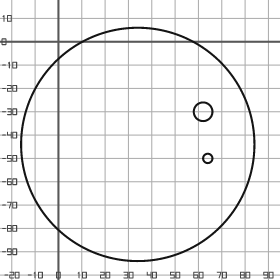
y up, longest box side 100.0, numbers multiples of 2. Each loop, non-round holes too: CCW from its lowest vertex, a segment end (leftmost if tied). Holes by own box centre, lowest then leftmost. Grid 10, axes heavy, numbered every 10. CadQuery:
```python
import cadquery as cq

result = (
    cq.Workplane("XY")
    .moveTo(34.0, -44.0)
    .circle(50.0)
    .moveTo(64.0, -50.0)
    .circle(2.0)
    .moveTo(62.0, -30.0)
    .circle(4.0)
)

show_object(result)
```